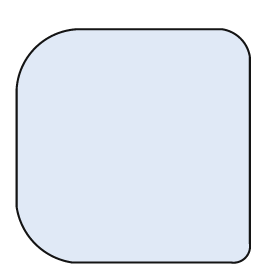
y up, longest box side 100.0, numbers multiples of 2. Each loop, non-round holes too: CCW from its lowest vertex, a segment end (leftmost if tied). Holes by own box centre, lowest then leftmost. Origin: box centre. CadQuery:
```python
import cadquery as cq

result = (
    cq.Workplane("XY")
    .moveTo(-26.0, -50.0)
    .lineTo(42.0, -50.0)
    .threePointArc((48.0, -48.0), (50.0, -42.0))
    .lineTo(50.0, 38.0)
    .threePointArc((46.0, 46.0), (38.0, 50.0))
    .lineTo(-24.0, 50.0)
    .threePointArc((-42.0, 42.0), (-50.0, 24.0))
    .lineTo(-50.0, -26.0)
    .threePointArc((-42.0, -42.0), (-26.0, -50.0))
    .close()
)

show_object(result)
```